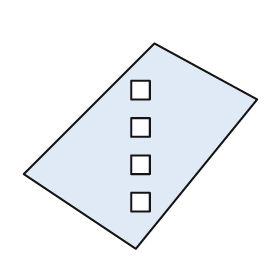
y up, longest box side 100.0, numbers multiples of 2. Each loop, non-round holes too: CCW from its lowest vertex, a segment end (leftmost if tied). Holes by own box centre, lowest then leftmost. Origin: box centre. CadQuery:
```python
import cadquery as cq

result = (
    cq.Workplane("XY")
    .moveTo(-2.0, -44.0)
    .lineTo(50.0, 20.0)
    .lineTo(6.0, 44.0)
    .lineTo(-50.0, -12.0)
    .close()
    .moveTo(-4.0, -28.0)
    .lineTo(4.0, -28.0)
    .lineTo(4.0, -20.0)
    .lineTo(-4.0, -20.0)
    .close()
    .moveTo(-4.0, -12.0)
    .lineTo(4.0, -12.0)
    .lineTo(4.0, -4.0)
    .lineTo(-4.0, -4.0)
    .close()
    .moveTo(-4.0, 4.0)
    .lineTo(4.0, 4.0)
    .lineTo(4.0, 12.0)
    .lineTo(-4.0, 12.0)
    .close()
    .moveTo(-4.0, 20.0)
    .lineTo(4.0, 20.0)
    .lineTo(4.0, 28.0)
    .lineTo(-4.0, 28.0)
    .close()
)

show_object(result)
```